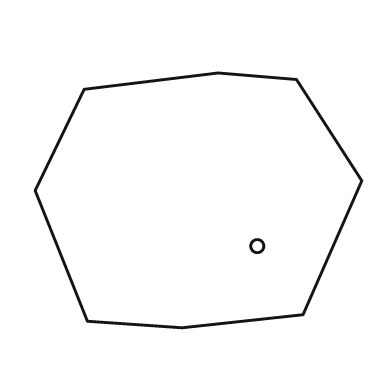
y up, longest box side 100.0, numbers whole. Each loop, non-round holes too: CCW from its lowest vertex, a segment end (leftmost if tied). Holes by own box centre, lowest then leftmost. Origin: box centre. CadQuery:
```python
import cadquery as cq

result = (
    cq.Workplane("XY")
    .moveTo(-5.0, -39.0)
    .lineTo(32.0, -35.0)
    .lineTo(50.0, 6.0)
    .lineTo(30.0, 37.0)
    .lineTo(6.0, 39.0)
    .lineTo(-35.0, 34.0)
    .lineTo(-50.0, 3.0)
    .lineTo(-34.0, -37.0)
    .close()
    .moveTo(18.0, -14.0)
    .circle(2.0)
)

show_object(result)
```